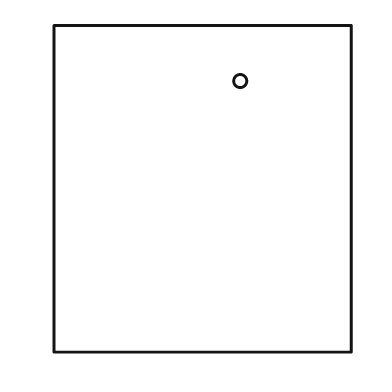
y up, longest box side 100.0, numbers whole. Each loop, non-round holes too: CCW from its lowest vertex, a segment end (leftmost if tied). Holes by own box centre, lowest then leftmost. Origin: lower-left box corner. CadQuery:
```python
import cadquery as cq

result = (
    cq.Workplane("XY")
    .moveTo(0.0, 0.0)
    .lineTo(91.0, 0.0)
    .lineTo(91.0, 100.0)
    .lineTo(0.0, 100.0)
    .close()
    .moveTo(57.0, 83.0)
    .circle(2.0)
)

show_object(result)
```